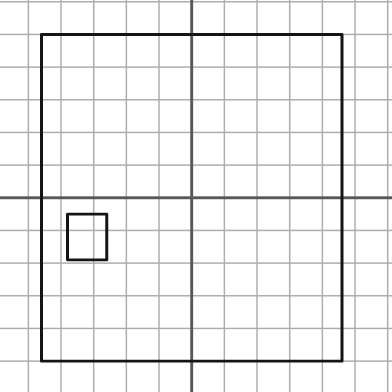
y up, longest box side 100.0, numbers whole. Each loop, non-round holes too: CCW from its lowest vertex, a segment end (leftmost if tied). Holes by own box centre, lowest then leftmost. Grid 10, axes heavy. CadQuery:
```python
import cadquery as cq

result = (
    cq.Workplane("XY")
    .moveTo(-46.0, -50.0)
    .lineTo(46.0, -50.0)
    .lineTo(46.0, 50.0)
    .lineTo(-46.0, 50.0)
    .close()
    .moveTo(-38.0, -19.0)
    .lineTo(-26.0, -19.0)
    .lineTo(-26.0, -5.0)
    .lineTo(-38.0, -5.0)
    .close()
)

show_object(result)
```